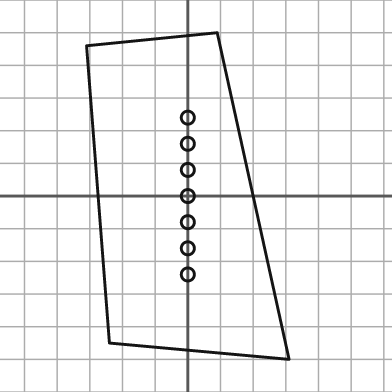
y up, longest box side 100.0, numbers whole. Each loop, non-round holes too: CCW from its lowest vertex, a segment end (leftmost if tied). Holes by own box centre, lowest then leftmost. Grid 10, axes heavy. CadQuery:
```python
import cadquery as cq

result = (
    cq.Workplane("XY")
    .moveTo(31.0, -50.0)
    .lineTo(9.0, 50.0)
    .lineTo(-31.0, 46.0)
    .lineTo(-24.0, -45.0)
    .close()
    .moveTo(0.0, -24.0)
    .circle(2.0)
    .moveTo(0.0, -16.0)
    .circle(2.0)
    .moveTo(0.0, -8.0)
    .circle(2.0)
    .moveTo(0.0, 0.0)
    .circle(2.0)
    .moveTo(0.0, 8.0)
    .circle(2.0)
    .moveTo(0.0, 16.0)
    .circle(2.0)
    .moveTo(0.0, 24.0)
    .circle(2.0)
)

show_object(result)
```